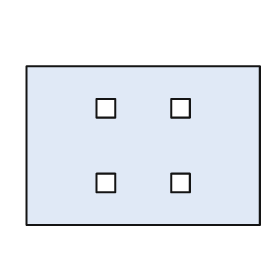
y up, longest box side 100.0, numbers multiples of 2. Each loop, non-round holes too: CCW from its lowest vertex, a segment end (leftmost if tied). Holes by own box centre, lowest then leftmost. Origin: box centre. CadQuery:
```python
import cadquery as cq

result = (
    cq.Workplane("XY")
    .moveTo(-50.0, -34.0)
    .lineTo(50.0, -34.0)
    .lineTo(50.0, 34.0)
    .lineTo(-50.0, 34.0)
    .close()
    .moveTo(-20.0, -20.0)
    .lineTo(-12.0, -20.0)
    .lineTo(-12.0, -12.0)
    .lineTo(-20.0, -12.0)
    .close()
    .moveTo(12.0, -20.0)
    .lineTo(20.0, -20.0)
    .lineTo(20.0, -12.0)
    .lineTo(12.0, -12.0)
    .close()
    .moveTo(-20.0, 12.0)
    .lineTo(-12.0, 12.0)
    .lineTo(-12.0, 20.0)
    .lineTo(-20.0, 20.0)
    .close()
    .moveTo(12.0, 12.0)
    .lineTo(20.0, 12.0)
    .lineTo(20.0, 20.0)
    .lineTo(12.0, 20.0)
    .close()
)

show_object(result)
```